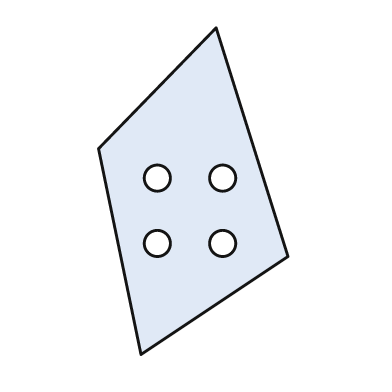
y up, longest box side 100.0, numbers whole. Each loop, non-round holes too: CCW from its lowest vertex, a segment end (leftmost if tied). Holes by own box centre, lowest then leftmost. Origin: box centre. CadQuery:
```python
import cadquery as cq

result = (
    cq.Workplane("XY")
    .moveTo(-16.0, -50.0)
    .lineTo(29.0, -20.0)
    .lineTo(7.0, 50.0)
    .lineTo(-29.0, 13.0)
    .close()
    .moveTo(-11.0, -16.0)
    .circle(4.0)
    .moveTo(9.0, -16.0)
    .circle(4.0)
    .moveTo(-11.0, 4.0)
    .circle(4.0)
    .moveTo(9.0, 4.0)
    .circle(4.0)
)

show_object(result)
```